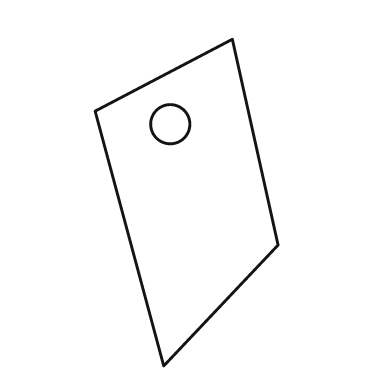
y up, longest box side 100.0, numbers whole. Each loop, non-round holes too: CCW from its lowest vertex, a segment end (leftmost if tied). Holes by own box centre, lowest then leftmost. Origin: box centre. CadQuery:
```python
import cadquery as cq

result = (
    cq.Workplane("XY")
    .moveTo(-7.0, -50.0)
    .lineTo(28.0, -13.0)
    .lineTo(14.0, 50.0)
    .lineTo(-28.0, 28.0)
    .close()
    .moveTo(-5.0, 24.0)
    .circle(6.0)
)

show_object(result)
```